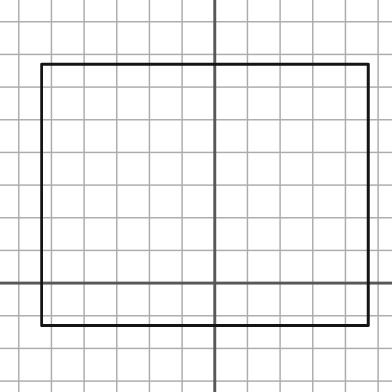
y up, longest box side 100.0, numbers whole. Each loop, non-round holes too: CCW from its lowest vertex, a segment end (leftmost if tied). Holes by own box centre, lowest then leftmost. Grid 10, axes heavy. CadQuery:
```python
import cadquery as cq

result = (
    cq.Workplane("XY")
    .moveTo(-53.0, -13.0)
    .lineTo(47.0, -13.0)
    .lineTo(47.0, 67.0)
    .lineTo(-53.0, 67.0)
    .close()
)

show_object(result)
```